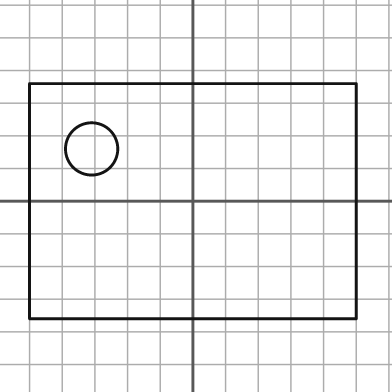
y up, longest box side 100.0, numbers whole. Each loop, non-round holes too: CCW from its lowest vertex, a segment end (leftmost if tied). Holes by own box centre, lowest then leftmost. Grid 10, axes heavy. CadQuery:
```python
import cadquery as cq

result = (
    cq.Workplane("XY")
    .moveTo(-50.0, -36.0)
    .lineTo(50.0, -36.0)
    .lineTo(50.0, 36.0)
    .lineTo(-50.0, 36.0)
    .close()
    .moveTo(-31.0, 16.0)
    .circle(8.0)
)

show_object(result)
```